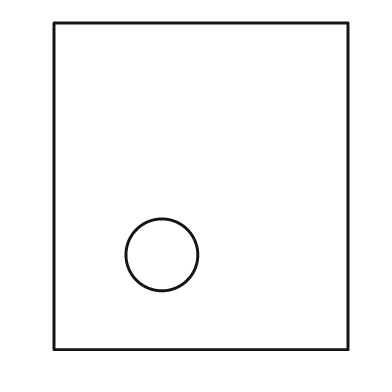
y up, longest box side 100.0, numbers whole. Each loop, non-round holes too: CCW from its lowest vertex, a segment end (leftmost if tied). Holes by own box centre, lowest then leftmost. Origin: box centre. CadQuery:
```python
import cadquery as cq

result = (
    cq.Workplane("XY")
    .moveTo(-45.0, -50.0)
    .lineTo(45.0, -50.0)
    .lineTo(45.0, 50.0)
    .lineTo(-45.0, 50.0)
    .close()
    .moveTo(-12.0, -21.0)
    .circle(11.0)
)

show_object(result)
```